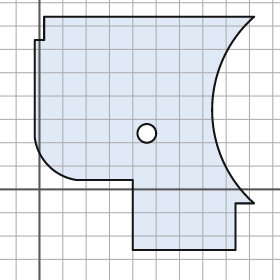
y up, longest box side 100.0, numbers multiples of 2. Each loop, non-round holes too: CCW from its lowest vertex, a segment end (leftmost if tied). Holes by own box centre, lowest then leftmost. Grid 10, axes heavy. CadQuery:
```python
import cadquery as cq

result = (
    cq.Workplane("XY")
    .moveTo(40.0, -26.0)
    .lineTo(84.0, -26.0)
    .lineTo(84.0, -6.0)
    .lineTo(92.0, -6.0)
    .threePointArc((74.0, 34.0), (92.0, 74.0))
    .lineTo(2.0, 74.0)
    .lineTo(2.0, 64.0)
    .lineTo(-2.0, 64.0)
    .lineTo(-2.0, 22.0)
    .threePointArc((4.0, 10.0), (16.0, 4.0))
    .lineTo(40.0, 4.0)
    .close()
    .moveTo(46.0, 24.0)
    .circle(4.0)
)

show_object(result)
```